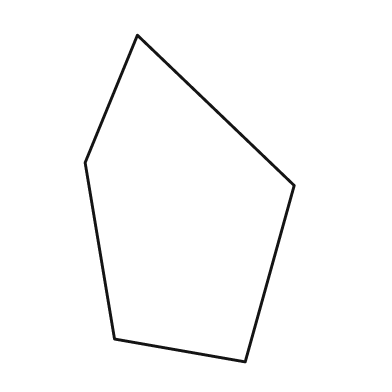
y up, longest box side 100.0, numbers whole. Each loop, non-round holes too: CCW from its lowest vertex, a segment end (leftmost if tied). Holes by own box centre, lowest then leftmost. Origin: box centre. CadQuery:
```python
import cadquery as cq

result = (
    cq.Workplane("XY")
    .moveTo(17.0, -50.0)
    .lineTo(32.0, 4.0)
    .lineTo(-16.0, 50.0)
    .lineTo(-32.0, 11.0)
    .lineTo(-23.0, -43.0)
    .close()
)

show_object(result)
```